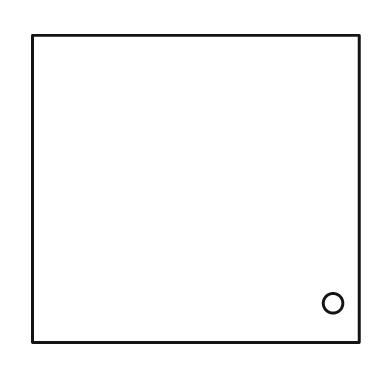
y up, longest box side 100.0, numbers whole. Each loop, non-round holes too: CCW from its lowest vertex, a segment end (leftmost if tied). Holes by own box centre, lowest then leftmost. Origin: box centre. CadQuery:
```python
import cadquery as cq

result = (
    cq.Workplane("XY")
    .moveTo(-50.0, -47.0)
    .lineTo(50.0, -47.0)
    .lineTo(50.0, 47.0)
    .lineTo(-50.0, 47.0)
    .close()
    .moveTo(42.0, -35.0)
    .circle(3.0)
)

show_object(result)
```